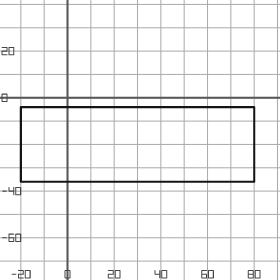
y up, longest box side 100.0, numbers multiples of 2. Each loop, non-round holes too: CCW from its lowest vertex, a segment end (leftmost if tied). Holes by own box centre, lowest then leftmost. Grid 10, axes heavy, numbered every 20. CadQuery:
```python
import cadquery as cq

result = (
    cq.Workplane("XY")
    .moveTo(-20.0, -36.0)
    .lineTo(80.0, -36.0)
    .lineTo(80.0, -4.0)
    .lineTo(-20.0, -4.0)
    .close()
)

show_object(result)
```